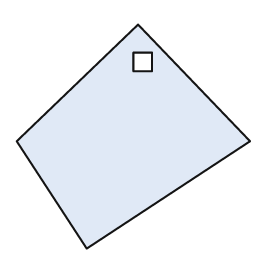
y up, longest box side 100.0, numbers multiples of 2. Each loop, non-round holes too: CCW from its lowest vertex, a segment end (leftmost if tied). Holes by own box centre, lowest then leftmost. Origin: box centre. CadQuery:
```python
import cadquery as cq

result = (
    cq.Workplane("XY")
    .moveTo(-20.0, -48.0)
    .lineTo(50.0, -2.0)
    .lineTo(2.0, 48.0)
    .lineTo(-50.0, -2.0)
    .close()
    .moveTo(0.0, 28.0)
    .lineTo(8.0, 28.0)
    .lineTo(8.0, 36.0)
    .lineTo(0.0, 36.0)
    .close()
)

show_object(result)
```